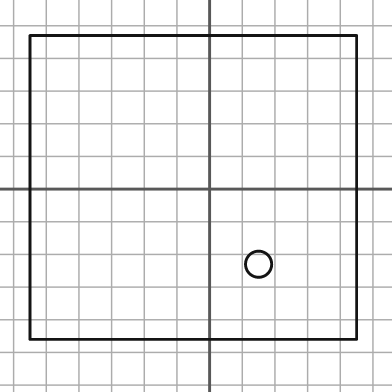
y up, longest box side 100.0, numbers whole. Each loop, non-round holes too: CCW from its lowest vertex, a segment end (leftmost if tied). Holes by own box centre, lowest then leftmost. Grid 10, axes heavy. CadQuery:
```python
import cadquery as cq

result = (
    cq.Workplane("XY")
    .moveTo(-55.0, -46.0)
    .lineTo(45.0, -46.0)
    .lineTo(45.0, 47.0)
    .lineTo(-55.0, 47.0)
    .close()
    .moveTo(15.0, -23.0)
    .circle(4.0)
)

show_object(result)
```